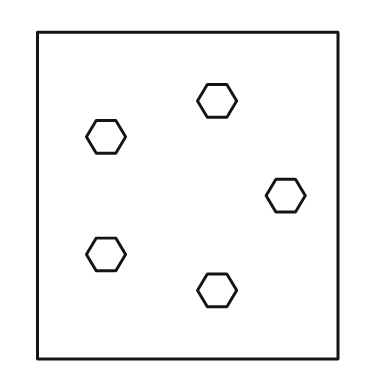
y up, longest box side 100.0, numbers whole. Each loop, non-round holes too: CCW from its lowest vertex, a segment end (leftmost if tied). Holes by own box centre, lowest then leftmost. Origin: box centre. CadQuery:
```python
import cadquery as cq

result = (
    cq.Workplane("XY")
    .moveTo(-46.0, -50.0)
    .lineTo(46.0, -50.0)
    .lineTo(46.0, 50.0)
    .lineTo(-46.0, 50.0)
    .close()
    .moveTo(6.0, -34.0)
    .lineTo(12.0, -34.0)
    .lineTo(15.0, -29.0)
    .lineTo(12.0, -24.0)
    .lineTo(6.0, -24.0)
    .lineTo(3.0, -29.0)
    .close()
    .moveTo(-28.0, -23.0)
    .lineTo(-22.0, -23.0)
    .lineTo(-19.0, -18.0)
    .lineTo(-22.0, -13.0)
    .lineTo(-28.0, -13.0)
    .lineTo(-31.0, -18.0)
    .close()
    .moveTo(27.0, -5.0)
    .lineTo(33.0, -5.0)
    .lineTo(36.0, 0.0)
    .lineTo(33.0, 5.0)
    .lineTo(27.0, 5.0)
    .lineTo(24.0, 0.0)
    .close()
    .moveTo(-28.0, 13.0)
    .lineTo(-22.0, 13.0)
    .lineTo(-19.0, 18.0)
    .lineTo(-22.0, 23.0)
    .lineTo(-28.0, 23.0)
    .lineTo(-31.0, 18.0)
    .close()
    .moveTo(6.0, 24.0)
    .lineTo(12.0, 24.0)
    .lineTo(15.0, 29.0)
    .lineTo(12.0, 34.0)
    .lineTo(6.0, 34.0)
    .lineTo(3.0, 29.0)
    .close()
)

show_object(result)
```